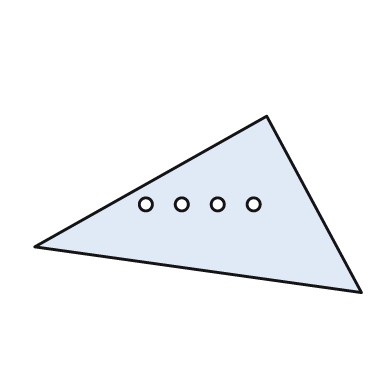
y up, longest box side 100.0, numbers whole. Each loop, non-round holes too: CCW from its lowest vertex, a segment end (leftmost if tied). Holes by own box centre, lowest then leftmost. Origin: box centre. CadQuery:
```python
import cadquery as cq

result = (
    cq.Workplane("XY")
    .moveTo(50.0, -27.0)
    .lineTo(21.0, 27.0)
    .lineTo(-50.0, -13.0)
    .close()
    .moveTo(-16.0, 0.0)
    .circle(2.0)
    .moveTo(-5.0, 0.0)
    .circle(2.0)
    .moveTo(6.0, 0.0)
    .circle(2.0)
    .moveTo(17.0, 0.0)
    .circle(2.0)
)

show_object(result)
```